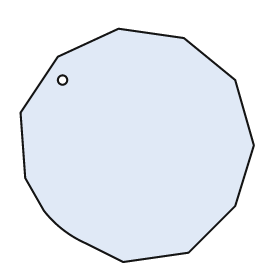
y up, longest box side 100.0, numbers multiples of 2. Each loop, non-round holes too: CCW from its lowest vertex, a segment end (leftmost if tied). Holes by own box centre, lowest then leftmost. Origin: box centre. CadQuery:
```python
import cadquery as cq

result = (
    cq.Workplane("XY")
    .moveTo(-6.0, -50.0)
    .lineTo(22.0, -46.0)
    .lineTo(42.0, -26.0)
    .lineTo(50.0, 0.0)
    .lineTo(42.0, 28.0)
    .lineTo(20.0, 46.0)
    .lineTo(-8.0, 50.0)
    .lineTo(-34.0, 38.0)
    .lineTo(-50.0, 14.0)
    .lineTo(-48.0, -14.0)
    .lineTo(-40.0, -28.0)
    .threePointArc((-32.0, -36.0), (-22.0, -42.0))
    .close()
    .moveTo(-32.0, 28.0)
    .circle(2.0)
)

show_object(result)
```